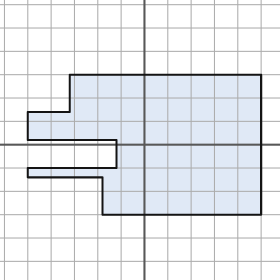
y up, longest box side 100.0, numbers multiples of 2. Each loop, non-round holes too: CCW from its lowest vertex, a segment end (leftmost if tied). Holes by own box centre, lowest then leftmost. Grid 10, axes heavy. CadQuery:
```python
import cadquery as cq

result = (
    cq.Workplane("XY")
    .moveTo(-18.0, -30.0)
    .lineTo(50.0, -30.0)
    .lineTo(50.0, 30.0)
    .lineTo(-32.0, 30.0)
    .lineTo(-32.0, 14.0)
    .lineTo(-50.0, 14.0)
    .lineTo(-50.0, 2.0)
    .lineTo(-12.0, 2.0)
    .lineTo(-12.0, -10.0)
    .lineTo(-50.0, -10.0)
    .lineTo(-50.0, -14.0)
    .lineTo(-18.0, -14.0)
    .close()
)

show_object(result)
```